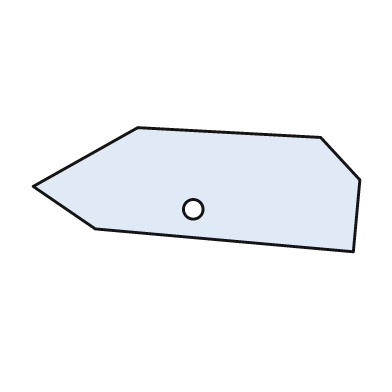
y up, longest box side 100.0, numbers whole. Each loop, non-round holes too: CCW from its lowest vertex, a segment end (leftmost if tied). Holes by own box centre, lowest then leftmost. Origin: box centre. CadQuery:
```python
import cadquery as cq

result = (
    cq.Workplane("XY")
    .moveTo(48.0, -19.0)
    .lineTo(50.0, 3.0)
    .lineTo(38.0, 16.0)
    .lineTo(-18.0, 19.0)
    .lineTo(-50.0, 1.0)
    .lineTo(-31.0, -12.0)
    .close()
    .moveTo(-1.0, -6.0)
    .circle(3.0)
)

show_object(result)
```